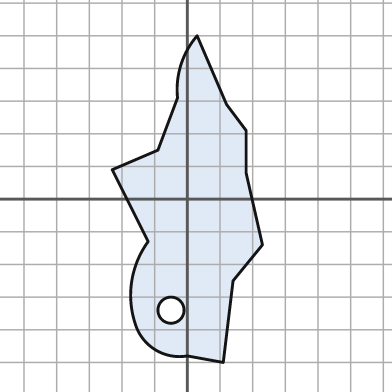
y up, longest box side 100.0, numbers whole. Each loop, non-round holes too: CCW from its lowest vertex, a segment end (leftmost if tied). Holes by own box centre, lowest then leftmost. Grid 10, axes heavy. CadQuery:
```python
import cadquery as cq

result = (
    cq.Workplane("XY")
    .moveTo(11.0, -50.0)
    .lineTo(14.0, -25.0)
    .lineTo(23.0, -14.0)
    .lineTo(18.0, 8.0)
    .lineTo(18.0, 21.0)
    .lineTo(12.0, 29.0)
    .lineTo(3.0, 50.0)
    .threePointArc((-2.0, 41.0), (-3.0, 31.0))
    .lineTo(-9.0, 15.0)
    .lineTo(-23.0, 9.0)
    .lineTo(-12.0, -13.0)
    .threePointArc((-17.0, -25.0), (-16.0, -38.0))
    .threePointArc((-10.0, -46.0), (0.0, -48.0))
    .close()
    .moveTo(-5.0, -34.0)
    .circle(4.0)
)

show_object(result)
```